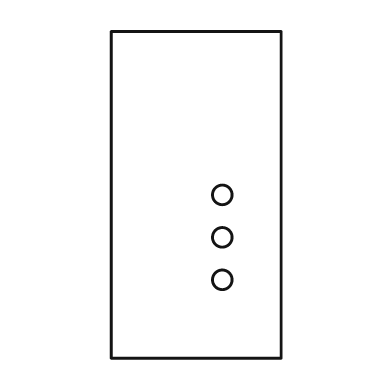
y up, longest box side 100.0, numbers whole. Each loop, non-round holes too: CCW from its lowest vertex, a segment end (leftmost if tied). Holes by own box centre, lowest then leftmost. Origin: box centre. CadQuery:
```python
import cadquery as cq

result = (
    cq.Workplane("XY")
    .moveTo(-26.0, -50.0)
    .lineTo(26.0, -50.0)
    .lineTo(26.0, 50.0)
    .lineTo(-26.0, 50.0)
    .close()
    .moveTo(8.0, -26.0)
    .circle(3.0)
    .moveTo(8.0, -13.0)
    .circle(3.0)
    .moveTo(8.0, 0.0)
    .circle(3.0)
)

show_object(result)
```